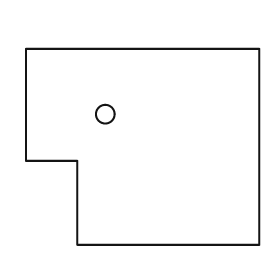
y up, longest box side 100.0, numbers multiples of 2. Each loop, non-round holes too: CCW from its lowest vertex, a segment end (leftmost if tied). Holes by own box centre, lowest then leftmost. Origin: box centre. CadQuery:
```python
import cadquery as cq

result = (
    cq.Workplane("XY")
    .moveTo(-28.0, -42.0)
    .lineTo(50.0, -42.0)
    .lineTo(50.0, 42.0)
    .lineTo(-50.0, 42.0)
    .lineTo(-50.0, -6.0)
    .lineTo(-28.0, -6.0)
    .close()
    .moveTo(-16.0, 14.0)
    .circle(4.0)
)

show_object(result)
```